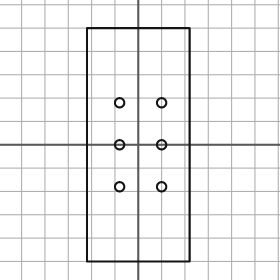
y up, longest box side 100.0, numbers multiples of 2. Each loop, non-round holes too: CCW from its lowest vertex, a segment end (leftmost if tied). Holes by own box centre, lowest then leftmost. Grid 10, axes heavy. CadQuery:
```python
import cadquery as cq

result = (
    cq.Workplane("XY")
    .moveTo(-22.0, -50.0)
    .lineTo(22.0, -50.0)
    .lineTo(22.0, 50.0)
    .lineTo(-22.0, 50.0)
    .close()
    .moveTo(-8.0, -18.0)
    .circle(2.0)
    .moveTo(10.0, -18.0)
    .circle(2.0)
    .moveTo(-8.0, 0.0)
    .circle(2.0)
    .moveTo(10.0, 0.0)
    .circle(2.0)
    .moveTo(-8.0, 18.0)
    .circle(2.0)
    .moveTo(10.0, 18.0)
    .circle(2.0)
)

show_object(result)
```